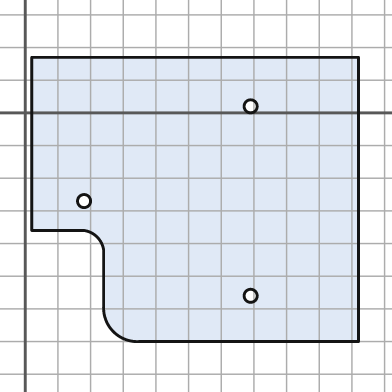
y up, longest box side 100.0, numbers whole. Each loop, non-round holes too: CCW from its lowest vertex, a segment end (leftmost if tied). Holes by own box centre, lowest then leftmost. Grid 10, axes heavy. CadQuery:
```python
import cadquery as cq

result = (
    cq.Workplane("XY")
    .moveTo(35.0, -70.0)
    .lineTo(102.0, -70.0)
    .lineTo(102.0, 17.0)
    .lineTo(2.0, 17.0)
    .lineTo(2.0, -36.0)
    .lineTo(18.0, -36.0)
    .threePointArc((22.0, -38.0), (24.0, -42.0))
    .lineTo(24.0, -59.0)
    .threePointArc((27.0, -67.0), (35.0, -70.0))
    .close()
    .moveTo(69.0, -56.0)
    .circle(2.0)
    .moveTo(18.0, -27.0)
    .circle(2.0)
    .moveTo(69.0, 2.0)
    .circle(2.0)
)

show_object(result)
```